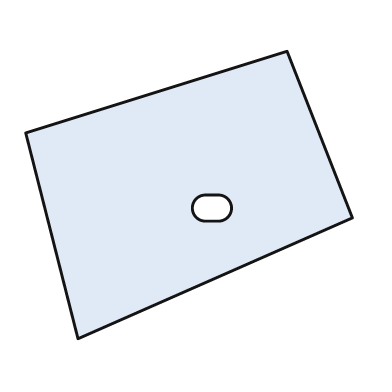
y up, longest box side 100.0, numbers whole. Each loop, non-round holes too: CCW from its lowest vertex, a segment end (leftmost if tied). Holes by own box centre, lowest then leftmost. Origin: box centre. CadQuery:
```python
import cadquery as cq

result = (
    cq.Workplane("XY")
    .moveTo(-34.0, -44.0)
    .lineTo(50.0, -7.0)
    .lineTo(30.0, 44.0)
    .lineTo(-50.0, 19.0)
    .close()
    .moveTo(5.0, -8.0)
    .lineTo(9.0, -8.0)
    .threePointArc((13.0, -4.0), (9.0, 0.0))
    .lineTo(5.0, 0.0)
    .threePointArc((1.0, -4.0), (5.0, -8.0))
    .close()
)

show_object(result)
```